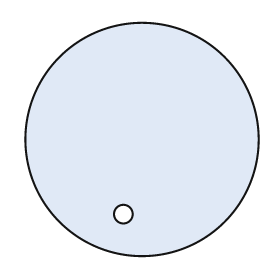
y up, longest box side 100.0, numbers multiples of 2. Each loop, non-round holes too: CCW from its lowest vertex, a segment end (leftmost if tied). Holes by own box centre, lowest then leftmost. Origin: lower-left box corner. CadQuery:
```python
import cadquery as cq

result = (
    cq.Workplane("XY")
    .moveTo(50.0, 50.0)
    .circle(50.0)
    .moveTo(42.0, 18.0)
    .circle(4.0)
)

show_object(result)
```